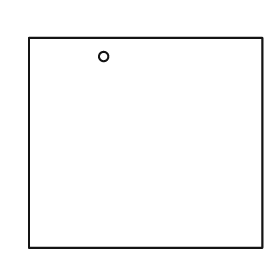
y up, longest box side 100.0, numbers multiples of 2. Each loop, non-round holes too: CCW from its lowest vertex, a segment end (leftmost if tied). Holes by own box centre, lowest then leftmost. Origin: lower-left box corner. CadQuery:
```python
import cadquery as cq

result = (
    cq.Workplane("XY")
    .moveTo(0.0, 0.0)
    .lineTo(100.0, 0.0)
    .lineTo(100.0, 90.0)
    .lineTo(0.0, 90.0)
    .close()
    .moveTo(32.0, 82.0)
    .circle(2.0)
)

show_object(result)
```